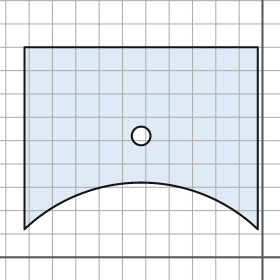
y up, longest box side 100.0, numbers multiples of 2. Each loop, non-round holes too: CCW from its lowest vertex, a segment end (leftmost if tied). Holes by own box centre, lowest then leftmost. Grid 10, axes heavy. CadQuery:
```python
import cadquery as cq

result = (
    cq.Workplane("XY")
    .moveTo(-102.0, 12.0)
    .threePointArc((-52.0, 32.0), (-2.0, 12.0))
    .lineTo(-2.0, 90.0)
    .lineTo(-102.0, 90.0)
    .close()
    .moveTo(-52.0, 52.0)
    .circle(4.0)
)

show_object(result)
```